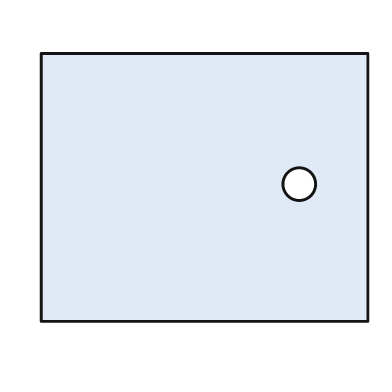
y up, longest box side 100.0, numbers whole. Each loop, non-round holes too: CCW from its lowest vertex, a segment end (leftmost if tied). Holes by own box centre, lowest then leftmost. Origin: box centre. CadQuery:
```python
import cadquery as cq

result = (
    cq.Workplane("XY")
    .moveTo(-50.0, -41.0)
    .lineTo(50.0, -41.0)
    .lineTo(50.0, 41.0)
    .lineTo(-50.0, 41.0)
    .close()
    .moveTo(29.0, 1.0)
    .circle(5.0)
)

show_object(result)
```